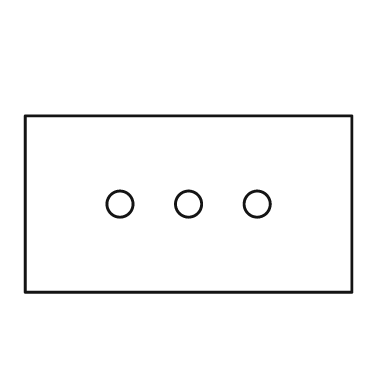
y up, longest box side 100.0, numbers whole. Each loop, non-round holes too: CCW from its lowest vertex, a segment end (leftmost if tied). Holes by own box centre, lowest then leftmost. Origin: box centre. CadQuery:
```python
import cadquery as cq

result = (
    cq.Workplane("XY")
    .moveTo(-50.0, -27.0)
    .lineTo(50.0, -27.0)
    .lineTo(50.0, 27.0)
    .lineTo(-50.0, 27.0)
    .close()
    .moveTo(-21.0, 0.0)
    .circle(4.0)
    .moveTo(0.0, 0.0)
    .circle(4.0)
    .moveTo(21.0, 0.0)
    .circle(4.0)
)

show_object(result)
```